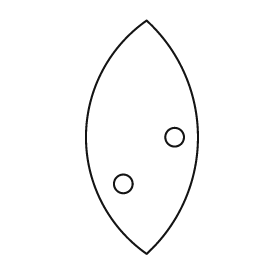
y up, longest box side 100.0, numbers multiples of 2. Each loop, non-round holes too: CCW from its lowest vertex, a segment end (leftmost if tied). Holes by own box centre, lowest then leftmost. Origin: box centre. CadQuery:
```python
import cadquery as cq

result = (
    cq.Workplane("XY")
    .moveTo(2.0, -50.0)
    .threePointArc((24.0, 0.0), (2.0, 50.0))
    .threePointArc((-24.0, 0.0), (2.0, -50.0))
    .close()
    .moveTo(-8.0, -20.0)
    .circle(4.0)
    .moveTo(14.0, 0.0)
    .circle(4.0)
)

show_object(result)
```